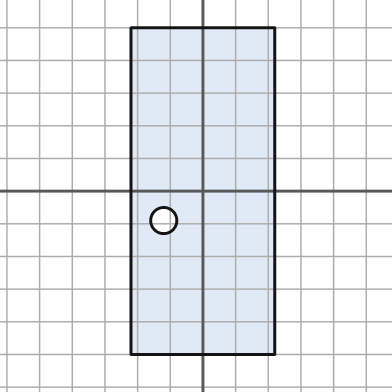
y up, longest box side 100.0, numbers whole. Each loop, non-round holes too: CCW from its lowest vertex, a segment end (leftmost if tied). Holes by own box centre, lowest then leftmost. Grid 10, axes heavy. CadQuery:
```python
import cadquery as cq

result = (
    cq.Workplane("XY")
    .moveTo(-22.0, -50.0)
    .lineTo(22.0, -50.0)
    .lineTo(22.0, 50.0)
    .lineTo(-22.0, 50.0)
    .close()
    .moveTo(-12.0, -9.0)
    .circle(4.0)
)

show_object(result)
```